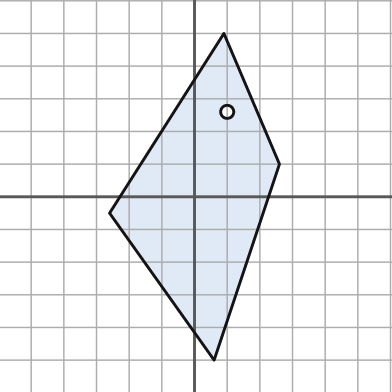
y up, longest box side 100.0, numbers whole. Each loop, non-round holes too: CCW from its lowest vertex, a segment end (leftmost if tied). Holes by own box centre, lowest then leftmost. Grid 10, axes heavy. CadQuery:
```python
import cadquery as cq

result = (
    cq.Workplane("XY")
    .moveTo(6.0, -50.0)
    .lineTo(26.0, 10.0)
    .lineTo(9.0, 50.0)
    .lineTo(-26.0, -5.0)
    .close()
    .moveTo(10.0, 26.0)
    .circle(2.0)
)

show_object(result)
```